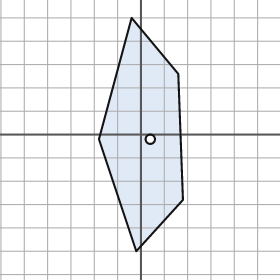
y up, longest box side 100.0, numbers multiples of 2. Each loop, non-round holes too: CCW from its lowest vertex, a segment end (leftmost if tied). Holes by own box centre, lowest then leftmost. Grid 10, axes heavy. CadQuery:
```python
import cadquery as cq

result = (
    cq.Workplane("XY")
    .moveTo(-2.0, -50.0)
    .lineTo(18.0, -28.0)
    .lineTo(16.0, 26.0)
    .lineTo(-4.0, 50.0)
    .lineTo(-18.0, -2.0)
    .close()
    .moveTo(4.0, -2.0)
    .circle(2.0)
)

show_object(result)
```